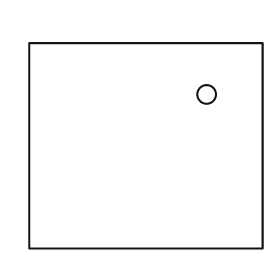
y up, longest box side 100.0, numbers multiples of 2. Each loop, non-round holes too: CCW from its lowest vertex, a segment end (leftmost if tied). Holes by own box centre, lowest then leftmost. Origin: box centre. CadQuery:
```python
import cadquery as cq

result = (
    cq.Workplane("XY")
    .moveTo(-50.0, -44.0)
    .lineTo(50.0, -44.0)
    .lineTo(50.0, 44.0)
    .lineTo(-50.0, 44.0)
    .close()
    .moveTo(26.0, 22.0)
    .circle(4.0)
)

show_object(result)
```